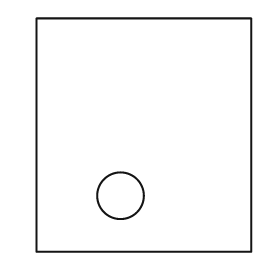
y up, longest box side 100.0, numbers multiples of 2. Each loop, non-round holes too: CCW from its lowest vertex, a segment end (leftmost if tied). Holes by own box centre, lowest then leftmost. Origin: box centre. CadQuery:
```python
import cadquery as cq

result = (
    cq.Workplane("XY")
    .moveTo(-46.0, -50.0)
    .lineTo(46.0, -50.0)
    .lineTo(46.0, 50.0)
    .lineTo(-46.0, 50.0)
    .close()
    .moveTo(-10.0, -26.0)
    .circle(10.0)
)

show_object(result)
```